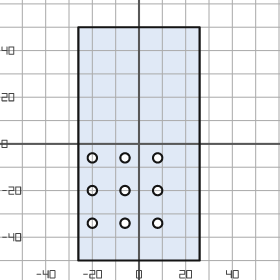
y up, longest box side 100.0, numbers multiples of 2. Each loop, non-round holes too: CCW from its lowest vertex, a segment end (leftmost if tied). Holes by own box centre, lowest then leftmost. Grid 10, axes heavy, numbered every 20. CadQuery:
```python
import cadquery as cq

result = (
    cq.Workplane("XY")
    .moveTo(-26.0, -50.0)
    .lineTo(26.0, -50.0)
    .lineTo(26.0, 50.0)
    .lineTo(-26.0, 50.0)
    .close()
    .moveTo(-20.0, -34.0)
    .circle(2.0)
    .moveTo(-6.0, -34.0)
    .circle(2.0)
    .moveTo(8.0, -34.0)
    .circle(2.0)
    .moveTo(-20.0, -20.0)
    .circle(2.0)
    .moveTo(-6.0, -20.0)
    .circle(2.0)
    .moveTo(8.0, -20.0)
    .circle(2.0)
    .moveTo(-20.0, -6.0)
    .circle(2.0)
    .moveTo(-6.0, -6.0)
    .circle(2.0)
    .moveTo(8.0, -6.0)
    .circle(2.0)
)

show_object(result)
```